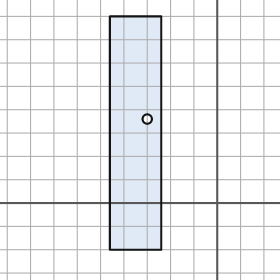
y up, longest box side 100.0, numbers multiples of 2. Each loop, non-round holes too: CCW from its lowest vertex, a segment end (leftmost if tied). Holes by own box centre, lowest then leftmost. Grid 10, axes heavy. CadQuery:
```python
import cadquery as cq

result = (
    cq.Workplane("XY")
    .moveTo(-46.0, -20.0)
    .lineTo(-24.0, -20.0)
    .lineTo(-24.0, 80.0)
    .lineTo(-46.0, 80.0)
    .close()
    .moveTo(-30.0, 36.0)
    .circle(2.0)
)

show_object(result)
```